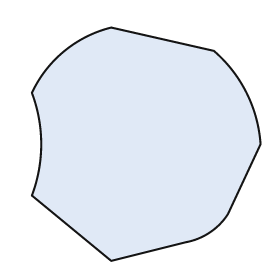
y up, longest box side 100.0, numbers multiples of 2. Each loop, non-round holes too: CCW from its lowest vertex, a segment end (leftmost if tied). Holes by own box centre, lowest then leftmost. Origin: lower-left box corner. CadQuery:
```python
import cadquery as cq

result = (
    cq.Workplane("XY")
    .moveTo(34.0, 0.0)
    .lineTo(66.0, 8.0)
    .threePointArc((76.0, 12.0), (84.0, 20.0))
    .lineTo(98.0, 50.0)
    .threePointArc((92.0, 72.0), (78.0, 90.0))
    .lineTo(34.0, 100.0)
    .threePointArc((14.0, 90.0), (0.0, 72.0))
    .threePointArc((4.0, 50.0), (0.0, 28.0))
    .close()
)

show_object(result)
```